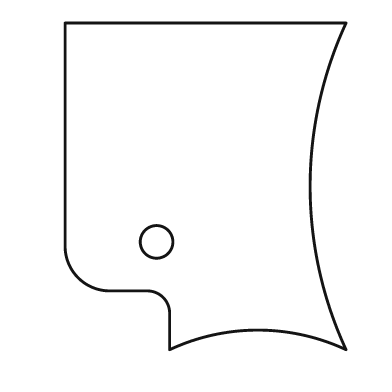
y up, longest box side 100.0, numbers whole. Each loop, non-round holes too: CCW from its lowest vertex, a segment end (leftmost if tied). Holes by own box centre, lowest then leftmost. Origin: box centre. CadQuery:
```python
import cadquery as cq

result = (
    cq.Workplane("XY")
    .moveTo(-11.0, -50.0)
    .threePointArc((16.0, -44.0), (43.0, -50.0))
    .threePointArc((32.0, 0.0), (43.0, 50.0))
    .lineTo(-43.0, 50.0)
    .lineTo(-43.0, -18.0)
    .threePointArc((-39.0, -28.0), (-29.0, -32.0))
    .lineTo(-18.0, -32.0)
    .threePointArc((-13.0, -34.0), (-11.0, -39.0))
    .close()
    .moveTo(-15.0, -17.0)
    .circle(5.0)
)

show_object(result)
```